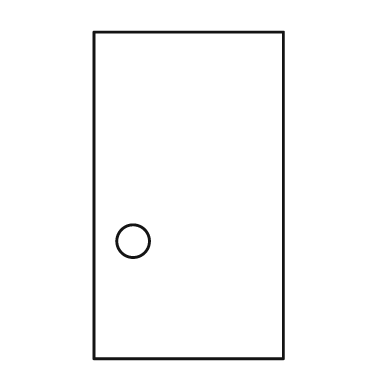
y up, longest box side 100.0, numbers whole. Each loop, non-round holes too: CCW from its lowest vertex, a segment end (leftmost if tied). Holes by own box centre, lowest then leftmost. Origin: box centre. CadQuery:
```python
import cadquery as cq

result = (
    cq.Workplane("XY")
    .moveTo(-29.0, -50.0)
    .lineTo(29.0, -50.0)
    .lineTo(29.0, 50.0)
    .lineTo(-29.0, 50.0)
    .close()
    .moveTo(-17.0, -14.0)
    .circle(5.0)
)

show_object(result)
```